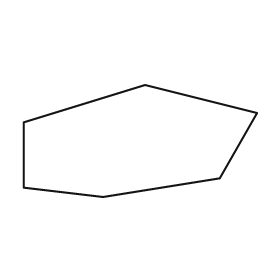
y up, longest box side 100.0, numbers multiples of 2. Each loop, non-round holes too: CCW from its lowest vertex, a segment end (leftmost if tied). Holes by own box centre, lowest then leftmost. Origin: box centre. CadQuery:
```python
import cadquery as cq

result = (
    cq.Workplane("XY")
    .moveTo(-16.0, -24.0)
    .lineTo(34.0, -16.0)
    .lineTo(50.0, 12.0)
    .lineTo(2.0, 24.0)
    .lineTo(-50.0, 8.0)
    .lineTo(-50.0, -20.0)
    .close()
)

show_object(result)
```